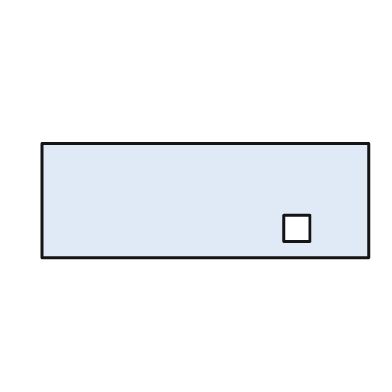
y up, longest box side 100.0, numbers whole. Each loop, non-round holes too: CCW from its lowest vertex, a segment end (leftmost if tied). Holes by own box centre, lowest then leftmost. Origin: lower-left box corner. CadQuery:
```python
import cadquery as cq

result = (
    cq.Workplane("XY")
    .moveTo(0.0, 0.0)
    .lineTo(100.0, 0.0)
    .lineTo(100.0, 35.0)
    .lineTo(0.0, 35.0)
    .close()
    .moveTo(74.0, 5.0)
    .lineTo(82.0, 5.0)
    .lineTo(82.0, 13.0)
    .lineTo(74.0, 13.0)
    .close()
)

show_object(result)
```